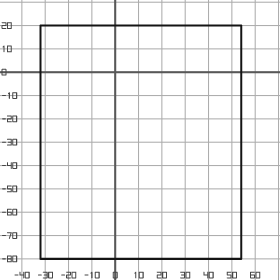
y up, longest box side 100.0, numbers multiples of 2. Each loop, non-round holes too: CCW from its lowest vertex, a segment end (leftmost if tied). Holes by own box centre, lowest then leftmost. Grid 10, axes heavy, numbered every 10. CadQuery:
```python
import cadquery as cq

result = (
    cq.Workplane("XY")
    .moveTo(-32.0, -80.0)
    .lineTo(54.0, -80.0)
    .lineTo(54.0, 20.0)
    .lineTo(-32.0, 20.0)
    .close()
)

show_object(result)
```